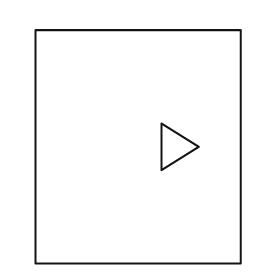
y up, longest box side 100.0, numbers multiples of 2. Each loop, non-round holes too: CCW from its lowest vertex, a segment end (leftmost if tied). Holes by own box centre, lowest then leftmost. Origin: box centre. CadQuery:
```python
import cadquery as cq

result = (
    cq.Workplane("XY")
    .moveTo(-44.0, -50.0)
    .lineTo(44.0, -50.0)
    .lineTo(44.0, 50.0)
    .lineTo(-44.0, 50.0)
    .close()
    .moveTo(10.0, -10.0)
    .lineTo(26.0, 0.0)
    .lineTo(10.0, 10.0)
    .close()
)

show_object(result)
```